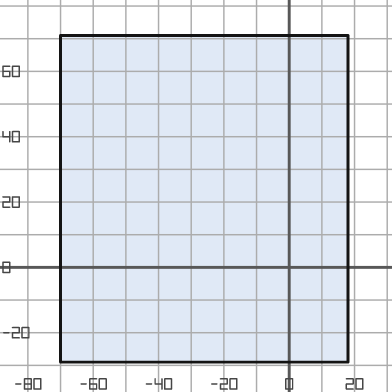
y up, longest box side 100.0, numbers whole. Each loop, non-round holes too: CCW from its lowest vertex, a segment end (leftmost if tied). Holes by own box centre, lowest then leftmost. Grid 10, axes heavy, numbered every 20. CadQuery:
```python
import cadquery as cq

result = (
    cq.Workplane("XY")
    .moveTo(-70.0, -29.0)
    .lineTo(18.0, -29.0)
    .lineTo(18.0, 71.0)
    .lineTo(-70.0, 71.0)
    .close()
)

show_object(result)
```